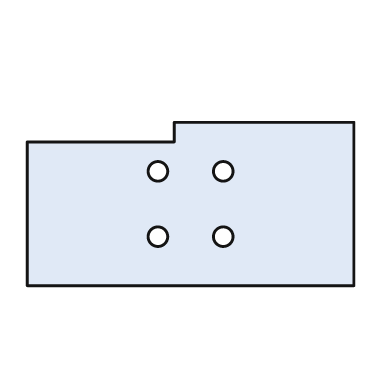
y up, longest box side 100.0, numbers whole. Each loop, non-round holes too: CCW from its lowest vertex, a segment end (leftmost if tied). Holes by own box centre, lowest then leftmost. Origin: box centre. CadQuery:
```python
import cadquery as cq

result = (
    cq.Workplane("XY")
    .moveTo(-50.0, -25.0)
    .lineTo(50.0, -25.0)
    .lineTo(50.0, 25.0)
    .lineTo(-5.0, 25.0)
    .lineTo(-5.0, 19.0)
    .lineTo(-50.0, 19.0)
    .close()
    .moveTo(-10.0, -10.0)
    .circle(3.0)
    .moveTo(10.0, -10.0)
    .circle(3.0)
    .moveTo(-10.0, 10.0)
    .circle(3.0)
    .moveTo(10.0, 10.0)
    .circle(3.0)
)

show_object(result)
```